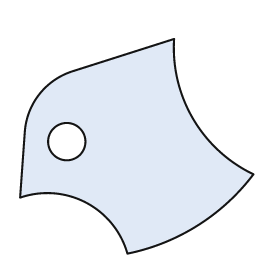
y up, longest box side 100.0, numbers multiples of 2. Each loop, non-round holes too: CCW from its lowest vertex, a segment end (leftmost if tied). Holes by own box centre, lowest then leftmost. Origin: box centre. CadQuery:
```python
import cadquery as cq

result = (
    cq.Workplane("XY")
    .moveTo(-4.0, -46.0)
    .threePointArc((26.0, -34.0), (50.0, -12.0))
    .threePointArc((24.0, 12.0), (16.0, 46.0))
    .lineTo(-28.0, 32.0)
    .threePointArc((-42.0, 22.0), (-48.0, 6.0))
    .lineTo(-50.0, -22.0)
    .threePointArc((-22.0, -24.0), (-4.0, -46.0))
    .close()
    .moveTo(-30.0, 2.0)
    .circle(8.0)
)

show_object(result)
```